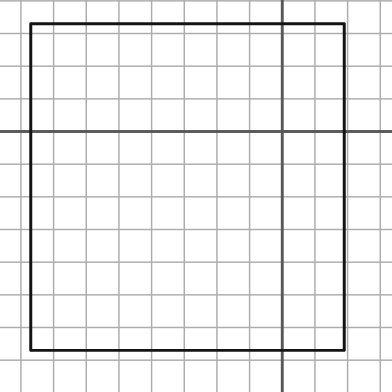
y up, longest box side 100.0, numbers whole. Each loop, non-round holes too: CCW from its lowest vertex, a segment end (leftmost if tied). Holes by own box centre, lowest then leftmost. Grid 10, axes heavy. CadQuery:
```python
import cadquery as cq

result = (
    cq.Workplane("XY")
    .moveTo(-77.0, -67.0)
    .lineTo(19.0, -67.0)
    .lineTo(19.0, 33.0)
    .lineTo(-77.0, 33.0)
    .close()
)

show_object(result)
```